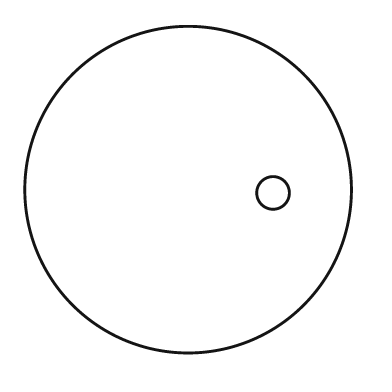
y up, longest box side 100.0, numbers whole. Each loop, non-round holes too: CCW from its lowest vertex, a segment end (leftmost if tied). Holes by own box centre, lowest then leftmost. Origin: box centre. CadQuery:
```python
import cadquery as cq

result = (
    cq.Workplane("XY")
    .moveTo(0.0, 0.0)
    .circle(50.0)
    .moveTo(26.0, -1.0)
    .circle(5.0)
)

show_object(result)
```